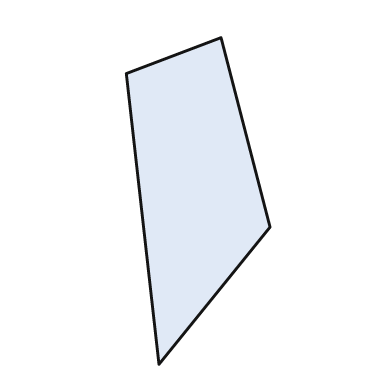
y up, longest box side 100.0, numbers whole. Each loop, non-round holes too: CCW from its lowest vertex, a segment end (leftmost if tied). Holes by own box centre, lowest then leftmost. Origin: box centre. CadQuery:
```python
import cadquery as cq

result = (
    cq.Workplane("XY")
    .moveTo(-12.0, -50.0)
    .lineTo(22.0, -8.0)
    .lineTo(7.0, 50.0)
    .lineTo(-22.0, 39.0)
    .close()
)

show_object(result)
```